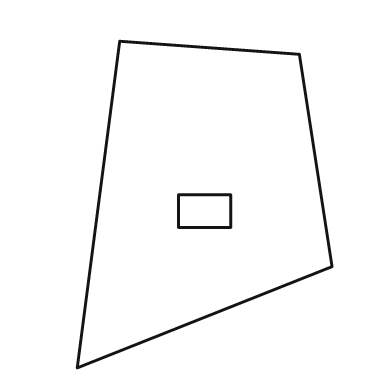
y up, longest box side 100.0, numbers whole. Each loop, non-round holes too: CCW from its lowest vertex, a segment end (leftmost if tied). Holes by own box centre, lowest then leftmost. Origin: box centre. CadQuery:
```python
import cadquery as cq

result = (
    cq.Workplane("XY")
    .moveTo(-39.0, -50.0)
    .lineTo(39.0, -19.0)
    .lineTo(29.0, 46.0)
    .lineTo(-26.0, 50.0)
    .close()
    .moveTo(-8.0, -7.0)
    .lineTo(8.0, -7.0)
    .lineTo(8.0, 3.0)
    .lineTo(-8.0, 3.0)
    .close()
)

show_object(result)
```